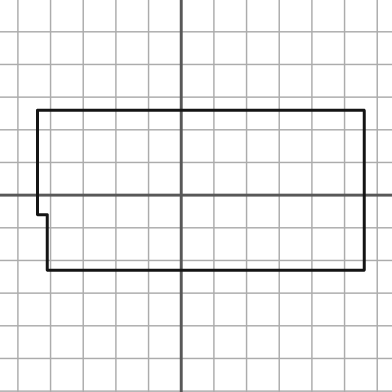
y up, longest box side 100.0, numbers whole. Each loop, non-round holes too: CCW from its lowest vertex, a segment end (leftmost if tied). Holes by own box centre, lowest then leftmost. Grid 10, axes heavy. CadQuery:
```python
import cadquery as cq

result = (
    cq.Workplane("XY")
    .moveTo(-41.0, -23.0)
    .lineTo(56.0, -23.0)
    .lineTo(56.0, 26.0)
    .lineTo(-44.0, 26.0)
    .lineTo(-44.0, -6.0)
    .lineTo(-41.0, -6.0)
    .close()
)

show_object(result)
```